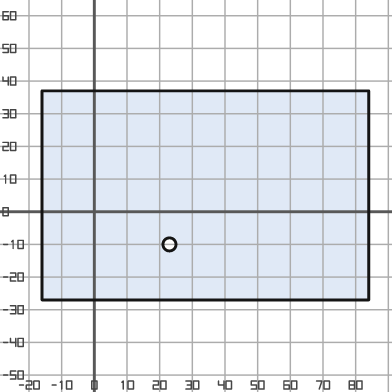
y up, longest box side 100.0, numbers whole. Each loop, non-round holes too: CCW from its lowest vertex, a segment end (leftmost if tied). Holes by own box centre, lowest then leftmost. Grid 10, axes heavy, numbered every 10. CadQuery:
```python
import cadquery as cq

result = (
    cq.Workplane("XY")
    .moveTo(-16.0, -27.0)
    .lineTo(84.0, -27.0)
    .lineTo(84.0, 37.0)
    .lineTo(-16.0, 37.0)
    .close()
    .moveTo(23.0, -10.0)
    .circle(2.0)
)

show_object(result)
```